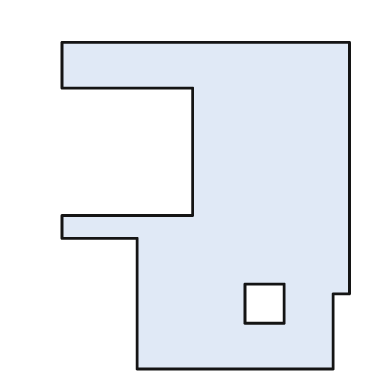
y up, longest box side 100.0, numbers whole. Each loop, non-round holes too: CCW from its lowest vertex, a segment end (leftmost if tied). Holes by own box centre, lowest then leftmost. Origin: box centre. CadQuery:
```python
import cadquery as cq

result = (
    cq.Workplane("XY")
    .moveTo(-21.0, -50.0)
    .lineTo(39.0, -50.0)
    .lineTo(39.0, -27.0)
    .lineTo(44.0, -27.0)
    .lineTo(44.0, 50.0)
    .lineTo(-44.0, 50.0)
    .lineTo(-44.0, 36.0)
    .lineTo(-4.0, 36.0)
    .lineTo(-4.0, -3.0)
    .lineTo(-44.0, -3.0)
    .lineTo(-44.0, -10.0)
    .lineTo(-21.0, -10.0)
    .close()
    .moveTo(12.0, -36.0)
    .lineTo(24.0, -36.0)
    .lineTo(24.0, -24.0)
    .lineTo(12.0, -24.0)
    .close()
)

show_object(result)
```